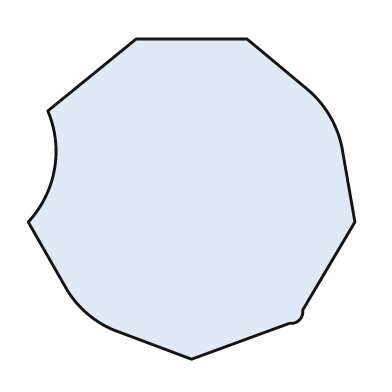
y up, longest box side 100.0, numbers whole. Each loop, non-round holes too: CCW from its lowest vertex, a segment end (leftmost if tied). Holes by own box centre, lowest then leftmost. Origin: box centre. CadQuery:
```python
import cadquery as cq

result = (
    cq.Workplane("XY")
    .moveTo(0.0, -49.0)
    .lineTo(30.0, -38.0)
    .threePointArc((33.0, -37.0), (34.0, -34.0))
    .lineTo(50.0, -7.0)
    .lineTo(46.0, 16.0)
    .threePointArc((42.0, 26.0), (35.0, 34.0))
    .lineTo(17.0, 49.0)
    .lineTo(-17.0, 49.0)
    .lineTo(-44.0, 27.0)
    .threePointArc((-42.0, 9.0), (-50.0, -7.0))
    .lineTo(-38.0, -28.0)
    .threePointArc((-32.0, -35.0), (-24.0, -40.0))
    .close()
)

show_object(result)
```